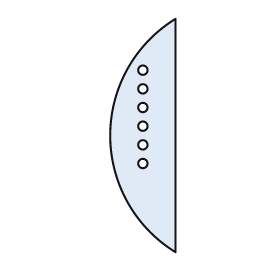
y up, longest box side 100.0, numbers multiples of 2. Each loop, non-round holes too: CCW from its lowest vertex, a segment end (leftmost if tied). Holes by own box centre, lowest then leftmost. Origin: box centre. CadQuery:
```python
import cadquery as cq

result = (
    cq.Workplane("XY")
    .moveTo(14.0, -50.0)
    .lineTo(14.0, 50.0)
    .threePointArc((-14.0, 0.0), (14.0, -50.0))
    .close()
    .moveTo(0.0, -12.0)
    .circle(2.0)
    .moveTo(0.0, -4.0)
    .circle(2.0)
    .moveTo(0.0, 4.0)
    .circle(2.0)
    .moveTo(0.0, 12.0)
    .circle(2.0)
    .moveTo(0.0, 20.0)
    .circle(2.0)
    .moveTo(0.0, 28.0)
    .circle(2.0)
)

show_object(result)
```